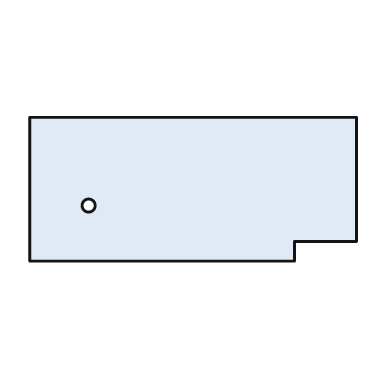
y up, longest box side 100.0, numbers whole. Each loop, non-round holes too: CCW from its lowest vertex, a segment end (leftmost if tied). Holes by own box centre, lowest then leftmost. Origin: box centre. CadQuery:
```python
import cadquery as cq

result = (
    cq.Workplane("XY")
    .moveTo(-50.0, -22.0)
    .lineTo(31.0, -22.0)
    .lineTo(31.0, -16.0)
    .lineTo(50.0, -16.0)
    .lineTo(50.0, 22.0)
    .lineTo(-50.0, 22.0)
    .close()
    .moveTo(-32.0, -5.0)
    .circle(2.0)
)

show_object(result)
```